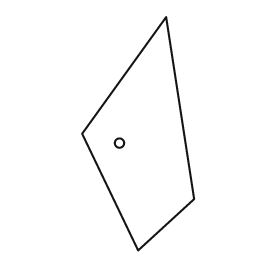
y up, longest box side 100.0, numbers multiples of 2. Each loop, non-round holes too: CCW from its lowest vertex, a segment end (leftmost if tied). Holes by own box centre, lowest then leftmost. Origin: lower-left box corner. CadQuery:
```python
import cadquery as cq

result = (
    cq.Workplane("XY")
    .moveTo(24.0, 0.0)
    .lineTo(48.0, 22.0)
    .lineTo(36.0, 100.0)
    .lineTo(0.0, 50.0)
    .close()
    .moveTo(16.0, 46.0)
    .circle(2.0)
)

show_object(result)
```